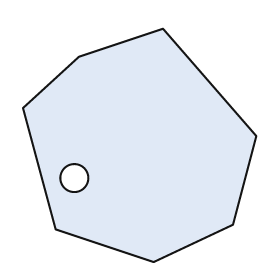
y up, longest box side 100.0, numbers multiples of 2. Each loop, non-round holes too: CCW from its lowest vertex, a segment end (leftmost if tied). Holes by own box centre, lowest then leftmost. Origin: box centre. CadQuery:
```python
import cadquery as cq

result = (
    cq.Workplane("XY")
    .moveTo(6.0, -50.0)
    .lineTo(40.0, -34.0)
    .lineTo(50.0, 4.0)
    .lineTo(10.0, 50.0)
    .lineTo(-26.0, 38.0)
    .lineTo(-50.0, 16.0)
    .lineTo(-36.0, -36.0)
    .close()
    .moveTo(-28.0, -14.0)
    .circle(6.0)
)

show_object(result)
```